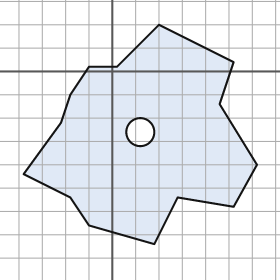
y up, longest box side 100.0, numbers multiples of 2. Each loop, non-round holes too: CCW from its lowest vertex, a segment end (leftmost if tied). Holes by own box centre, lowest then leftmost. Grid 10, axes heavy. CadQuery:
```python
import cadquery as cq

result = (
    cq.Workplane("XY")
    .moveTo(18.0, -74.0)
    .lineTo(28.0, -54.0)
    .lineTo(52.0, -58.0)
    .lineTo(62.0, -40.0)
    .lineTo(46.0, -14.0)
    .lineTo(52.0, 4.0)
    .lineTo(20.0, 20.0)
    .lineTo(2.0, 2.0)
    .lineTo(-10.0, 2.0)
    .lineTo(-18.0, -10.0)
    .lineTo(-22.0, -22.0)
    .lineTo(-38.0, -44.0)
    .lineTo(-18.0, -54.0)
    .lineTo(-10.0, -66.0)
    .close()
    .moveTo(12.0, -26.0)
    .circle(6.0)
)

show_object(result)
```